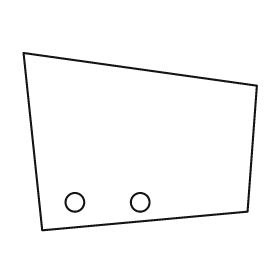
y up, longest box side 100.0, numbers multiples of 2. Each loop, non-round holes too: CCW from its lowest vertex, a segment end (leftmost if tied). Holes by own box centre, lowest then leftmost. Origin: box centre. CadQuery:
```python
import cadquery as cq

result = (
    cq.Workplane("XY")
    .moveTo(-42.0, -38.0)
    .lineTo(46.0, -30.0)
    .lineTo(50.0, 24.0)
    .lineTo(-50.0, 38.0)
    .close()
    .moveTo(-28.0, -26.0)
    .circle(4.0)
    .moveTo(0.0, -26.0)
    .circle(4.0)
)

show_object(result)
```